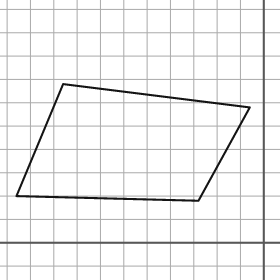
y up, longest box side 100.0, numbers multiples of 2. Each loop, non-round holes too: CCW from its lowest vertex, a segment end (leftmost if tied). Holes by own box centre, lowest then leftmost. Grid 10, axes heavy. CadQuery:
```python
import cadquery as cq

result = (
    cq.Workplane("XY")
    .moveTo(-28.0, 18.0)
    .lineTo(-6.0, 58.0)
    .lineTo(-86.0, 68.0)
    .lineTo(-106.0, 20.0)
    .close()
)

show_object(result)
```